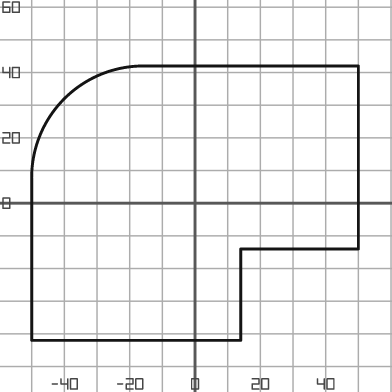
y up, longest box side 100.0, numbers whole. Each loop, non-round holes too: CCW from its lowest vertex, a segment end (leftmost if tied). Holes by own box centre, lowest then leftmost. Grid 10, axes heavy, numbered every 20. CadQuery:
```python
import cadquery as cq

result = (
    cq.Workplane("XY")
    .moveTo(-50.0, -42.0)
    .lineTo(14.0, -42.0)
    .lineTo(14.0, -14.0)
    .lineTo(50.0, -14.0)
    .lineTo(50.0, 42.0)
    .lineTo(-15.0, 42.0)
    .threePointArc((-40.0, 32.0), (-50.0, 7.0))
    .close()
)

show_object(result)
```